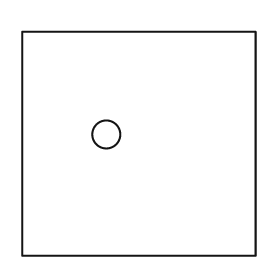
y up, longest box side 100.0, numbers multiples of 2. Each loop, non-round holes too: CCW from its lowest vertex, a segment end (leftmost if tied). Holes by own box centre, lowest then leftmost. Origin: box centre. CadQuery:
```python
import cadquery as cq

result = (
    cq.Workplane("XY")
    .moveTo(-50.0, -48.0)
    .lineTo(50.0, -48.0)
    .lineTo(50.0, 48.0)
    .lineTo(-50.0, 48.0)
    .close()
    .moveTo(-14.0, 4.0)
    .circle(6.0)
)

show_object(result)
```